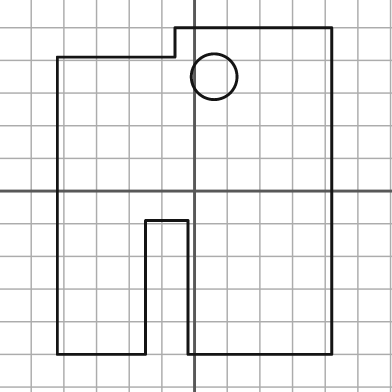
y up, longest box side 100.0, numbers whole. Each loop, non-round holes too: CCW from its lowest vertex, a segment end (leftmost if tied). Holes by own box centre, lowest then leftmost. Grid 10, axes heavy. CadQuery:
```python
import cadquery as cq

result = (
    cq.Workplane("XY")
    .moveTo(-42.0, -50.0)
    .lineTo(-15.0, -50.0)
    .lineTo(-15.0, -9.0)
    .lineTo(-2.0, -9.0)
    .lineTo(-2.0, -50.0)
    .lineTo(42.0, -50.0)
    .lineTo(42.0, 50.0)
    .lineTo(-6.0, 50.0)
    .lineTo(-6.0, 41.0)
    .lineTo(-42.0, 41.0)
    .close()
    .moveTo(6.0, 35.0)
    .circle(7.0)
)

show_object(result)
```